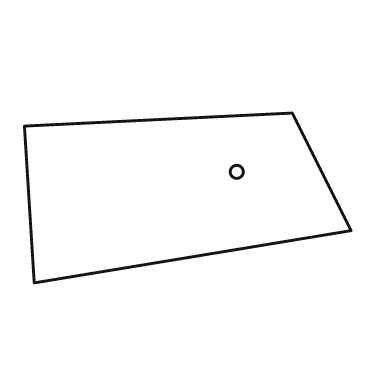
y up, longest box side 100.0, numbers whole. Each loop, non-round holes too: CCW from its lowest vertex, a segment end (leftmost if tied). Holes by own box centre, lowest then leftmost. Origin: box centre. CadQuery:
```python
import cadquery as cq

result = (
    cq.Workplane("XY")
    .moveTo(-47.0, -26.0)
    .lineTo(50.0, -10.0)
    .lineTo(32.0, 26.0)
    .lineTo(-50.0, 22.0)
    .close()
    .moveTo(15.0, 8.0)
    .circle(2.0)
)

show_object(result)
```